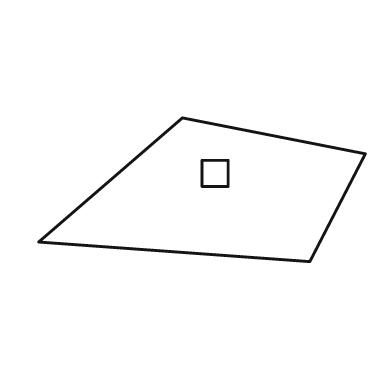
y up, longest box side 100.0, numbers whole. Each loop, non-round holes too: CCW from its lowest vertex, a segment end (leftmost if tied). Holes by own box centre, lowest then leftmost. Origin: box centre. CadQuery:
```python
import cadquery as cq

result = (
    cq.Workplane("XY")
    .moveTo(33.0, -22.0)
    .lineTo(50.0, 11.0)
    .lineTo(-6.0, 22.0)
    .lineTo(-50.0, -16.0)
    .close()
    .moveTo(0.0, 1.0)
    .lineTo(8.0, 1.0)
    .lineTo(8.0, 9.0)
    .lineTo(0.0, 9.0)
    .close()
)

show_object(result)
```